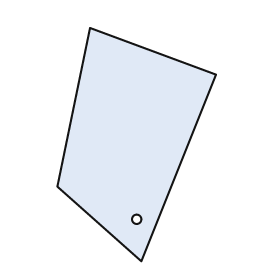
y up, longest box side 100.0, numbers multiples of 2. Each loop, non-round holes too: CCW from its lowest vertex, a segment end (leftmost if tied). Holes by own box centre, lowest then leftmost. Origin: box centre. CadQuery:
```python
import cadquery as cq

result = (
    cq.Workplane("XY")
    .moveTo(2.0, -50.0)
    .lineTo(34.0, 30.0)
    .lineTo(-20.0, 50.0)
    .lineTo(-34.0, -18.0)
    .close()
    .moveTo(0.0, -32.0)
    .circle(2.0)
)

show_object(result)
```